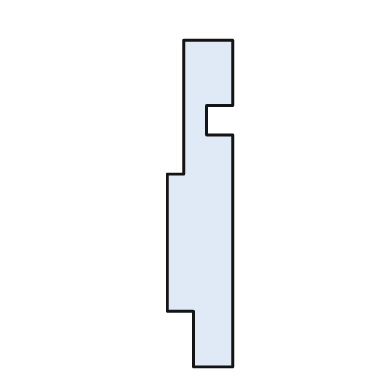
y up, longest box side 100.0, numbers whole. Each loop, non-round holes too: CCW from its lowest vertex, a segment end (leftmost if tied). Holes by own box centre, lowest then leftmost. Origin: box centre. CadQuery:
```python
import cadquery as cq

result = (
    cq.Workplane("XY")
    .moveTo(-2.0, -50.0)
    .lineTo(10.0, -50.0)
    .lineTo(10.0, 21.0)
    .lineTo(2.0, 21.0)
    .lineTo(2.0, 30.0)
    .lineTo(10.0, 30.0)
    .lineTo(10.0, 50.0)
    .lineTo(-5.0, 50.0)
    .lineTo(-5.0, 9.0)
    .lineTo(-10.0, 9.0)
    .lineTo(-10.0, -33.0)
    .lineTo(-2.0, -33.0)
    .close()
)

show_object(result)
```